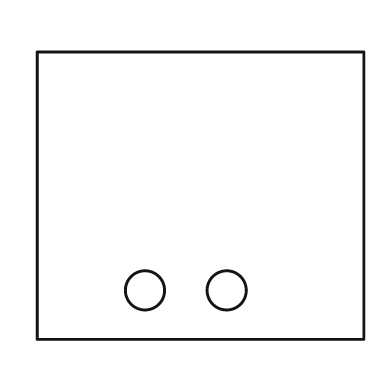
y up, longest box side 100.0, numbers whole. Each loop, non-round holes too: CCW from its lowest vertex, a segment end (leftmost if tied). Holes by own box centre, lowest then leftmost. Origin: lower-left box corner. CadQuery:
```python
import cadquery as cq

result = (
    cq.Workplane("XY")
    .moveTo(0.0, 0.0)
    .lineTo(100.0, 0.0)
    .lineTo(100.0, 88.0)
    .lineTo(0.0, 88.0)
    .close()
    .moveTo(33.0, 15.0)
    .circle(6.0)
    .moveTo(58.0, 15.0)
    .circle(6.0)
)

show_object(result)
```